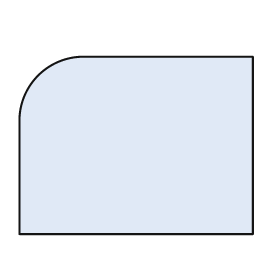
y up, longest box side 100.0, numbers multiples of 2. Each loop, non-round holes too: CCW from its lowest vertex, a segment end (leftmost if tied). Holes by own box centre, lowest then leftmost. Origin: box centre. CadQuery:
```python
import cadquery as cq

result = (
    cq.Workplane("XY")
    .moveTo(-50.0, -38.0)
    .lineTo(50.0, -38.0)
    .lineTo(50.0, 38.0)
    .lineTo(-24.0, 38.0)
    .threePointArc((-42.0, 30.0), (-50.0, 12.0))
    .close()
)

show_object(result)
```